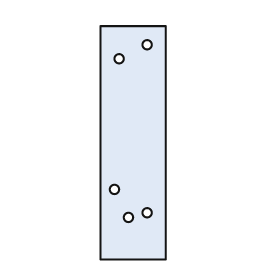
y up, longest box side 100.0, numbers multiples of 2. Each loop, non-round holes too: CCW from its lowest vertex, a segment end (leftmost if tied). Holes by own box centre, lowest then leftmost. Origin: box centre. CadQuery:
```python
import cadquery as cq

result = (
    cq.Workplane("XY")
    .moveTo(-14.0, -50.0)
    .lineTo(14.0, -50.0)
    .lineTo(14.0, 50.0)
    .lineTo(-14.0, 50.0)
    .close()
    .moveTo(-2.0, -32.0)
    .circle(2.0)
    .moveTo(6.0, -30.0)
    .circle(2.0)
    .moveTo(-8.0, -20.0)
    .circle(2.0)
    .moveTo(-6.0, 36.0)
    .circle(2.0)
    .moveTo(6.0, 42.0)
    .circle(2.0)
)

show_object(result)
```